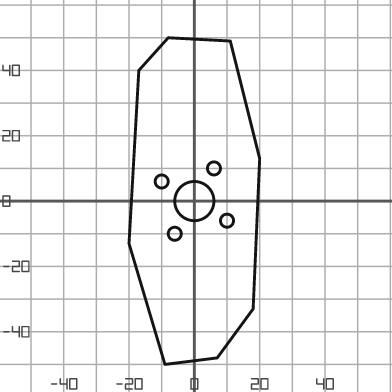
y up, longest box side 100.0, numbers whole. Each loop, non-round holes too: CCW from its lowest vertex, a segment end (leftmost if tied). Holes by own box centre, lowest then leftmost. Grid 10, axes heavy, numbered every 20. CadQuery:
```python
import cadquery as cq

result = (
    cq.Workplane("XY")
    .moveTo(-9.0, -50.0)
    .lineTo(7.0, -48.0)
    .lineTo(18.0, -33.0)
    .lineTo(20.0, 13.0)
    .lineTo(11.0, 49.0)
    .lineTo(-8.0, 50.0)
    .lineTo(-17.0, 40.0)
    .lineTo(-20.0, -13.0)
    .close()
    .moveTo(-6.0, -10.0)
    .circle(2.0)
    .moveTo(10.0, -6.0)
    .circle(2.0)
    .moveTo(0.0, 0.0)
    .circle(6.0)
    .moveTo(-10.0, 6.0)
    .circle(2.0)
    .moveTo(6.0, 10.0)
    .circle(2.0)
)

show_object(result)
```